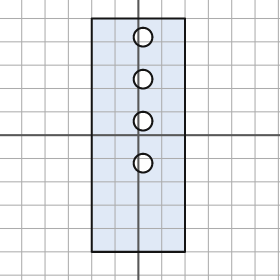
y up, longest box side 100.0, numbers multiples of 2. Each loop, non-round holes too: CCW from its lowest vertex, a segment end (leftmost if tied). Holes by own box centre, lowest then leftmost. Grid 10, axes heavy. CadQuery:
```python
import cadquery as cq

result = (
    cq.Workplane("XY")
    .moveTo(-20.0, -50.0)
    .lineTo(20.0, -50.0)
    .lineTo(20.0, 50.0)
    .lineTo(-20.0, 50.0)
    .close()
    .moveTo(2.0, -12.0)
    .circle(4.0)
    .moveTo(2.0, 6.0)
    .circle(4.0)
    .moveTo(2.0, 24.0)
    .circle(4.0)
    .moveTo(2.0, 42.0)
    .circle(4.0)
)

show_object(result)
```